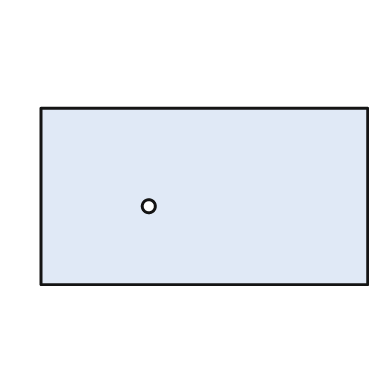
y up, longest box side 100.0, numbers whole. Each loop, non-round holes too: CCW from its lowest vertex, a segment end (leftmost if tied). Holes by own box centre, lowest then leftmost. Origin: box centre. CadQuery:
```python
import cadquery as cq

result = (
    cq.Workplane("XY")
    .moveTo(-50.0, -27.0)
    .lineTo(50.0, -27.0)
    .lineTo(50.0, 27.0)
    .lineTo(-50.0, 27.0)
    .close()
    .moveTo(-17.0, -3.0)
    .circle(2.0)
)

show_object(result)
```